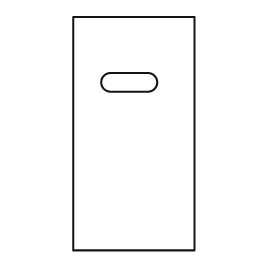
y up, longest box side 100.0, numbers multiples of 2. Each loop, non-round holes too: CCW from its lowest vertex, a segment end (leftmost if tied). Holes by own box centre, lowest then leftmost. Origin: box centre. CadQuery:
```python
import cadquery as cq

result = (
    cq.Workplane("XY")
    .moveTo(-26.0, -50.0)
    .lineTo(26.0, -50.0)
    .lineTo(26.0, 50.0)
    .lineTo(-26.0, 50.0)
    .close()
    .moveTo(-10.0, 18.0)
    .lineTo(6.0, 18.0)
    .threePointArc((10.0, 22.0), (6.0, 26.0))
    .lineTo(-10.0, 26.0)
    .threePointArc((-14.0, 22.0), (-10.0, 18.0))
    .close()
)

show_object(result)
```